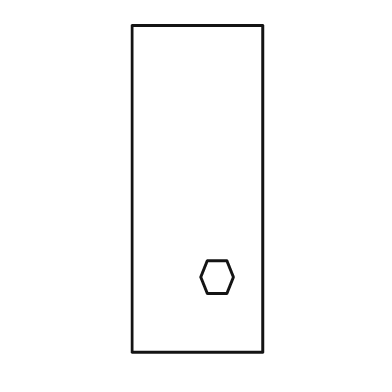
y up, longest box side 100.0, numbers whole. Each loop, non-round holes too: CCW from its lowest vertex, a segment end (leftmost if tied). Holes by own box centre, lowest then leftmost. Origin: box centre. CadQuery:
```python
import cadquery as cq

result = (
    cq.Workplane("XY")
    .moveTo(-20.0, -50.0)
    .lineTo(20.0, -50.0)
    .lineTo(20.0, 50.0)
    .lineTo(-20.0, 50.0)
    .close()
    .moveTo(3.0, -32.0)
    .lineTo(9.0, -32.0)
    .lineTo(11.0, -27.0)
    .lineTo(9.0, -22.0)
    .lineTo(3.0, -22.0)
    .lineTo(1.0, -27.0)
    .close()
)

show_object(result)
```